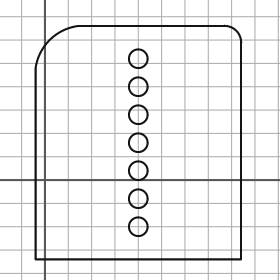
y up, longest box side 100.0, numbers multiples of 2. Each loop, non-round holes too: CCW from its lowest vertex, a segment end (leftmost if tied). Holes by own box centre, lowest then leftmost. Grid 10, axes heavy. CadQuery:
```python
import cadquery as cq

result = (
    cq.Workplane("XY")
    .moveTo(-4.0, -34.0)
    .lineTo(84.0, -34.0)
    .lineTo(84.0, 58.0)
    .threePointArc((82.0, 64.0), (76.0, 66.0))
    .lineTo(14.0, 66.0)
    .threePointArc((2.0, 60.0), (-4.0, 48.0))
    .close()
    .moveTo(40.0, -20.0)
    .circle(4.0)
    .moveTo(40.0, -8.0)
    .circle(4.0)
    .moveTo(40.0, 4.0)
    .circle(4.0)
    .moveTo(40.0, 16.0)
    .circle(4.0)
    .moveTo(40.0, 28.0)
    .circle(4.0)
    .moveTo(40.0, 40.0)
    .circle(4.0)
    .moveTo(40.0, 52.0)
    .circle(4.0)
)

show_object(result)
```